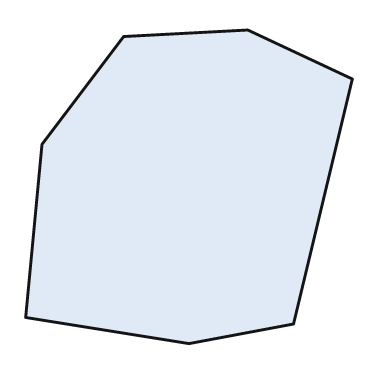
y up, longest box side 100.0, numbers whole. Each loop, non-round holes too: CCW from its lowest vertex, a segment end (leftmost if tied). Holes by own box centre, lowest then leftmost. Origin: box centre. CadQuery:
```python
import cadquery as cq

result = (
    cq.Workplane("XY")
    .moveTo(0.0, -48.0)
    .lineTo(32.0, -42.0)
    .lineTo(50.0, 33.0)
    .lineTo(18.0, 48.0)
    .lineTo(-20.0, 46.0)
    .lineTo(-45.0, 13.0)
    .lineTo(-50.0, -40.0)
    .close()
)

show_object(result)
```